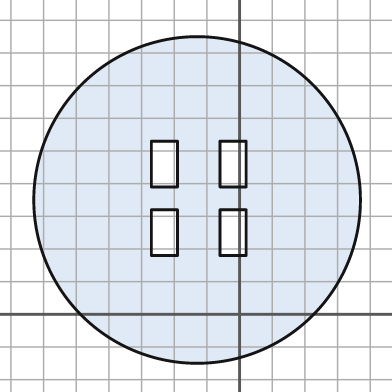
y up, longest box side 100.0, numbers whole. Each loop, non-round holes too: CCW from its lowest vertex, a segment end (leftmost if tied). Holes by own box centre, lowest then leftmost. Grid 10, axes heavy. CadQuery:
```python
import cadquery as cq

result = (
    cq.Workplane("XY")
    .moveTo(-13.0, 35.0)
    .circle(50.0)
    .moveTo(-27.0, 18.0)
    .lineTo(-19.0, 18.0)
    .lineTo(-19.0, 32.0)
    .lineTo(-27.0, 32.0)
    .close()
    .moveTo(-6.0, 18.0)
    .lineTo(2.0, 18.0)
    .lineTo(2.0, 32.0)
    .lineTo(-6.0, 32.0)
    .close()
    .moveTo(-27.0, 39.0)
    .lineTo(-19.0, 39.0)
    .lineTo(-19.0, 53.0)
    .lineTo(-27.0, 53.0)
    .close()
    .moveTo(-6.0, 39.0)
    .lineTo(2.0, 39.0)
    .lineTo(2.0, 53.0)
    .lineTo(-6.0, 53.0)
    .close()
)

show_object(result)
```